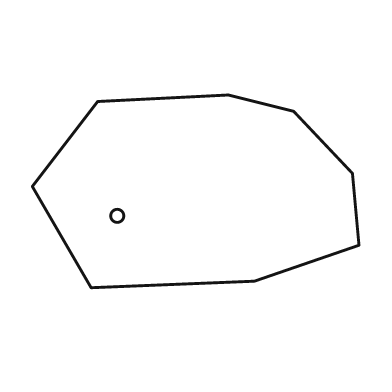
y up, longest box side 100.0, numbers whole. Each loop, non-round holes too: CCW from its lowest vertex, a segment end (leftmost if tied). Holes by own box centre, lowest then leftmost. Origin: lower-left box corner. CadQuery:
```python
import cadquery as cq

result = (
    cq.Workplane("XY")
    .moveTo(18.0, 0.0)
    .lineTo(68.0, 2.0)
    .lineTo(100.0, 13.0)
    .lineTo(98.0, 35.0)
    .lineTo(80.0, 54.0)
    .lineTo(60.0, 59.0)
    .lineTo(20.0, 57.0)
    .lineTo(0.0, 31.0)
    .close()
    .moveTo(26.0, 22.0)
    .circle(2.0)
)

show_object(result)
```